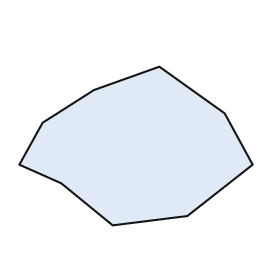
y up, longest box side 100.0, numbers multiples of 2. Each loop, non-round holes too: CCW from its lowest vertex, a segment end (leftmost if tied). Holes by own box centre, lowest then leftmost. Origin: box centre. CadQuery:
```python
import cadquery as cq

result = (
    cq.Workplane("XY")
    .moveTo(-10.0, -34.0)
    .lineTo(22.0, -30.0)
    .lineTo(50.0, -8.0)
    .lineTo(38.0, 14.0)
    .lineTo(10.0, 34.0)
    .lineTo(-18.0, 24.0)
    .lineTo(-40.0, 10.0)
    .lineTo(-50.0, -8.0)
    .lineTo(-32.0, -16.0)
    .close()
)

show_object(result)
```